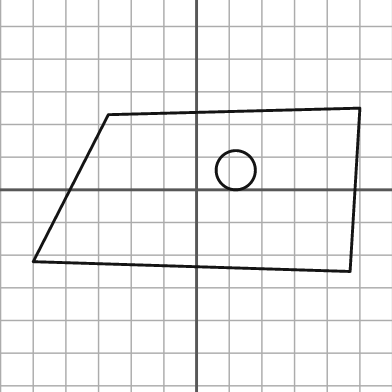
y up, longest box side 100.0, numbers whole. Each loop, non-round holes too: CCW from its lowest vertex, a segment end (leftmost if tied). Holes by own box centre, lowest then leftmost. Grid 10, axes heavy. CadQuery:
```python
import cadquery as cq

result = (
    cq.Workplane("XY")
    .moveTo(47.0, -25.0)
    .lineTo(50.0, 25.0)
    .lineTo(-27.0, 23.0)
    .lineTo(-50.0, -22.0)
    .close()
    .moveTo(12.0, 6.0)
    .circle(6.0)
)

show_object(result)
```